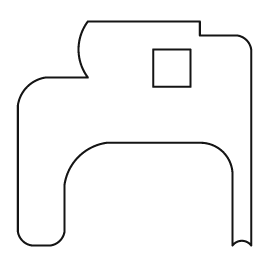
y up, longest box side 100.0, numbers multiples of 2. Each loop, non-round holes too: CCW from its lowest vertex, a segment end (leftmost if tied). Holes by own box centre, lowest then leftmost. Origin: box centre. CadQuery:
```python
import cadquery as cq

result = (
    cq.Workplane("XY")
    .moveTo(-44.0, -48.0)
    .lineTo(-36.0, -48.0)
    .threePointArc((-32.0, -46.0), (-30.0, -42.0))
    .lineTo(-30.0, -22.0)
    .threePointArc((-24.0, -10.0), (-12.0, -4.0))
    .lineTo(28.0, -4.0)
    .threePointArc((38.0, -8.0), (42.0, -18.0))
    .lineTo(42.0, -48.0)
    .threePointArc((46.0, -46.0), (50.0, -48.0))
    .lineTo(50.0, 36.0)
    .threePointArc((48.0, 40.0), (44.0, 42.0))
    .lineTo(28.0, 42.0)
    .lineTo(28.0, 48.0)
    .lineTo(-20.0, 48.0)
    .threePointArc((-24.0, 36.0), (-20.0, 24.0))
    .lineTo(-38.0, 24.0)
    .threePointArc((-46.0, 20.0), (-50.0, 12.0))
    .lineTo(-50.0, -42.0)
    .threePointArc((-48.0, -46.0), (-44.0, -48.0))
    .close()
    .moveTo(8.0, 20.0)
    .lineTo(24.0, 20.0)
    .lineTo(24.0, 36.0)
    .lineTo(8.0, 36.0)
    .close()
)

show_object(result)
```